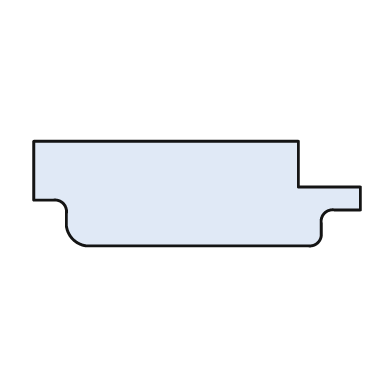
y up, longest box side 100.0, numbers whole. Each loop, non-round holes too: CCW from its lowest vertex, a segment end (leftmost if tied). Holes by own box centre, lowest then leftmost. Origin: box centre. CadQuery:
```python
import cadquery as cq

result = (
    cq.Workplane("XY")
    .moveTo(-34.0, -16.0)
    .lineTo(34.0, -16.0)
    .threePointArc((37.0, -15.0), (38.0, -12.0))
    .lineTo(38.0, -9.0)
    .threePointArc((39.0, -6.0), (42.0, -5.0))
    .lineTo(50.0, -5.0)
    .lineTo(50.0, 2.0)
    .lineTo(31.0, 2.0)
    .lineTo(31.0, 16.0)
    .lineTo(-50.0, 16.0)
    .lineTo(-50.0, -2.0)
    .lineTo(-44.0, -2.0)
    .threePointArc((-41.0, -3.0), (-40.0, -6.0))
    .lineTo(-40.0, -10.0)
    .threePointArc((-38.0, -14.0), (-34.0, -16.0))
    .close()
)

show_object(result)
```